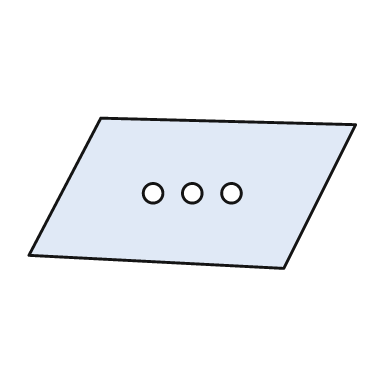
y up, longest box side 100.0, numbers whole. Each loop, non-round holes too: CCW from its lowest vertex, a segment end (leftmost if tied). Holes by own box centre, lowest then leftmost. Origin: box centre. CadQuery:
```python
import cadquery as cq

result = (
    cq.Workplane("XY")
    .moveTo(28.0, -23.0)
    .lineTo(50.0, 21.0)
    .lineTo(-28.0, 23.0)
    .lineTo(-50.0, -19.0)
    .close()
    .moveTo(-12.0, 0.0)
    .circle(3.0)
    .moveTo(0.0, 0.0)
    .circle(3.0)
    .moveTo(12.0, 0.0)
    .circle(3.0)
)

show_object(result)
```